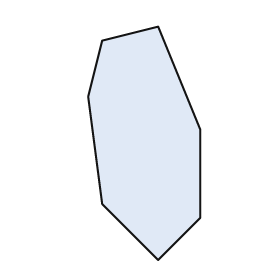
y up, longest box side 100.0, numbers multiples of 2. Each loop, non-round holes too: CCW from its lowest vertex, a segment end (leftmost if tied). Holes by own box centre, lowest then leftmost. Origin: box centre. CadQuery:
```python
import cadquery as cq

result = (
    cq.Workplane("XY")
    .moveTo(6.0, -50.0)
    .lineTo(24.0, -32.0)
    .lineTo(24.0, 6.0)
    .lineTo(6.0, 50.0)
    .lineTo(-18.0, 44.0)
    .lineTo(-24.0, 20.0)
    .lineTo(-18.0, -26.0)
    .close()
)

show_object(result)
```